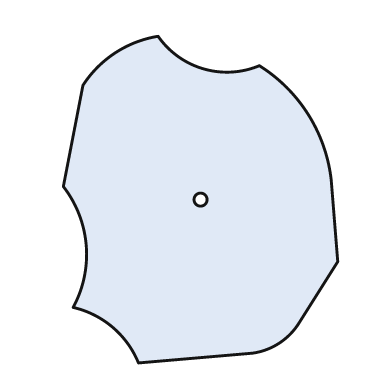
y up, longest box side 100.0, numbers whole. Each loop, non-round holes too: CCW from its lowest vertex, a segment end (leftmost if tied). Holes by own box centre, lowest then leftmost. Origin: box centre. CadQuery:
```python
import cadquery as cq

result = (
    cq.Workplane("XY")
    .moveTo(-19.0, -50.0)
    .lineTo(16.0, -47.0)
    .threePointArc((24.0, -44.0), (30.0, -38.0))
    .lineTo(42.0, -19.0)
    .lineTo(40.0, 6.0)
    .threePointArc((33.0, 26.0), (18.0, 41.0))
    .threePointArc((1.0, 40.0), (-13.0, 50.0))
    .threePointArc((-26.0, 45.0), (-36.0, 35.0))
    .lineTo(-42.0, 4.0)
    .threePointArc((-35.0, -14.0), (-39.0, -33.0))
    .threePointArc((-27.0, -39.0), (-19.0, -50.0))
    .close()
    .moveTo(0.0, 0.0)
    .circle(2.0)
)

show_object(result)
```